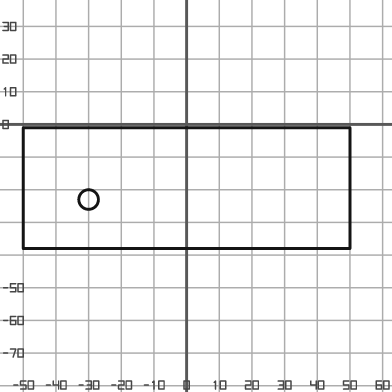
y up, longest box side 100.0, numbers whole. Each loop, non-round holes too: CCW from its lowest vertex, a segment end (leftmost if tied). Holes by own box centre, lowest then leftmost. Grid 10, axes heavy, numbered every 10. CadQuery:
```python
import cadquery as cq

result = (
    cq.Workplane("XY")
    .moveTo(-50.0, -38.0)
    .lineTo(50.0, -38.0)
    .lineTo(50.0, -1.0)
    .lineTo(-50.0, -1.0)
    .close()
    .moveTo(-30.0, -23.0)
    .circle(3.0)
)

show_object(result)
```